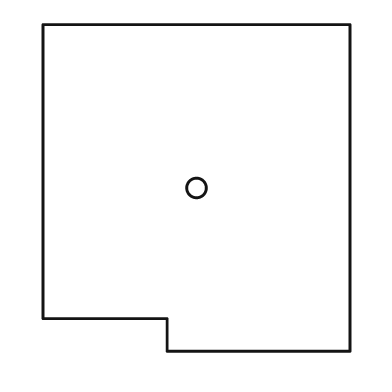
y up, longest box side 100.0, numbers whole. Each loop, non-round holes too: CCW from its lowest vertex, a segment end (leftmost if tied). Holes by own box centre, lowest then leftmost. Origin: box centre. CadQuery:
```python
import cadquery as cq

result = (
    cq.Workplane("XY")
    .moveTo(-9.0, -50.0)
    .lineTo(47.0, -50.0)
    .lineTo(47.0, 50.0)
    .lineTo(-47.0, 50.0)
    .lineTo(-47.0, -40.0)
    .lineTo(-9.0, -40.0)
    .close()
    .moveTo(0.0, 0.0)
    .circle(3.0)
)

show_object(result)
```